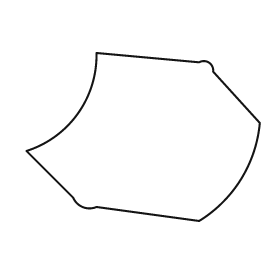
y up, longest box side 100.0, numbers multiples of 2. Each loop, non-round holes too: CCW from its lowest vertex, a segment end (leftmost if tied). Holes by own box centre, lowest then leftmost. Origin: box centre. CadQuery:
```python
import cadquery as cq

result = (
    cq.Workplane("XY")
    .moveTo(24.0, -36.0)
    .threePointArc((42.0, -18.0), (50.0, 6.0))
    .lineTo(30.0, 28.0)
    .threePointArc((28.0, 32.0), (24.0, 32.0))
    .lineTo(-20.0, 36.0)
    .threePointArc((-28.0, 10.0), (-50.0, -6.0))
    .lineTo(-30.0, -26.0)
    .threePointArc((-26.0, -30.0), (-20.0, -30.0))
    .close()
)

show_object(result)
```